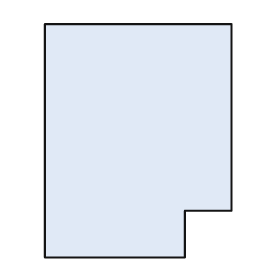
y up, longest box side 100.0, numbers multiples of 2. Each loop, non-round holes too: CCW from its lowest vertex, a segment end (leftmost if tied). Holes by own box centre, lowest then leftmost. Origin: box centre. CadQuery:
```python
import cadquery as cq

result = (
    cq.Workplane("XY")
    .moveTo(-40.0, -50.0)
    .lineTo(20.0, -50.0)
    .lineTo(20.0, -30.0)
    .lineTo(40.0, -30.0)
    .lineTo(40.0, 50.0)
    .lineTo(-40.0, 50.0)
    .close()
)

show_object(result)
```